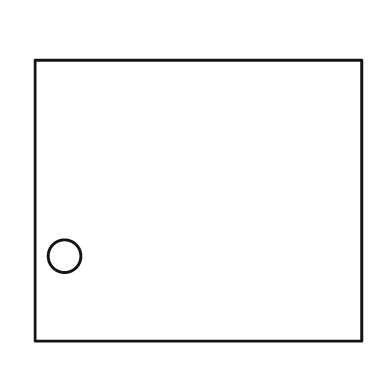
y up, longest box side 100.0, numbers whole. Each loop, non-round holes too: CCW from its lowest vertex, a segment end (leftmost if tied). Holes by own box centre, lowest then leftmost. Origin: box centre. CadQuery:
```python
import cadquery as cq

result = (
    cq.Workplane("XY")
    .moveTo(-50.0, -43.0)
    .lineTo(50.0, -43.0)
    .lineTo(50.0, 43.0)
    .lineTo(-50.0, 43.0)
    .close()
    .moveTo(-41.0, -17.0)
    .circle(5.0)
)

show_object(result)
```